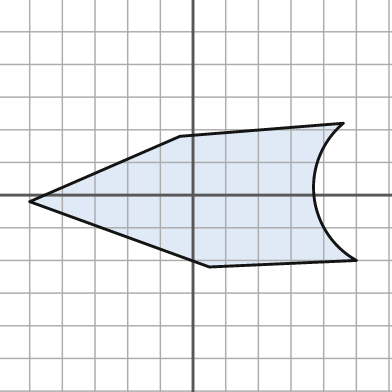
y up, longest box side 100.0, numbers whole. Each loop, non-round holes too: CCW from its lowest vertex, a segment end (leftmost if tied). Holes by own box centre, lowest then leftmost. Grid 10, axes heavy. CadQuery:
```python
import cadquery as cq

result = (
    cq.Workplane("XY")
    .moveTo(5.0, -22.0)
    .lineTo(50.0, -20.0)
    .threePointArc((37.0, 0.0), (46.0, 22.0))
    .lineTo(-4.0, 18.0)
    .lineTo(-50.0, -2.0)
    .close()
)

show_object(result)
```